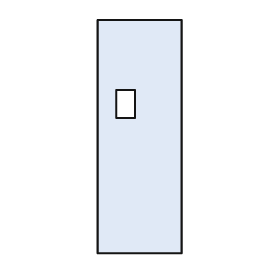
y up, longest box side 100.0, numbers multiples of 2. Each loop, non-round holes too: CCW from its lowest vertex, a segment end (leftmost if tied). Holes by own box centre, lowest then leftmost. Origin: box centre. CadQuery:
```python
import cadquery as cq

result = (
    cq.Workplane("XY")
    .moveTo(-18.0, -50.0)
    .lineTo(18.0, -50.0)
    .lineTo(18.0, 50.0)
    .lineTo(-18.0, 50.0)
    .close()
    .moveTo(-10.0, 8.0)
    .lineTo(-2.0, 8.0)
    .lineTo(-2.0, 20.0)
    .lineTo(-10.0, 20.0)
    .close()
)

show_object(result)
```